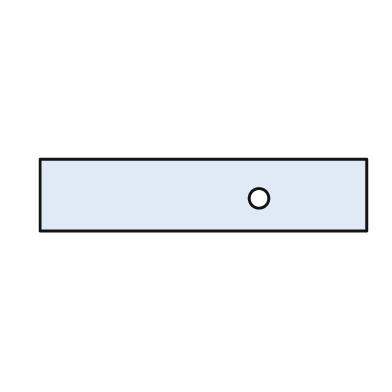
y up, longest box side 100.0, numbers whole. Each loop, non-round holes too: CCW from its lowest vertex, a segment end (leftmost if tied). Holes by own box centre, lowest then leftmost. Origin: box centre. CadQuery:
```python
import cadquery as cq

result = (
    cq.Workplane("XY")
    .moveTo(-50.0, -11.0)
    .lineTo(50.0, -11.0)
    .lineTo(50.0, 11.0)
    .lineTo(-50.0, 11.0)
    .close()
    .moveTo(17.0, -1.0)
    .circle(3.0)
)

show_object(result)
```